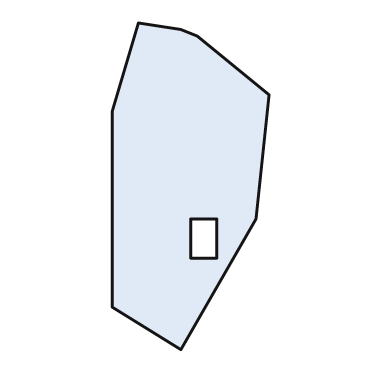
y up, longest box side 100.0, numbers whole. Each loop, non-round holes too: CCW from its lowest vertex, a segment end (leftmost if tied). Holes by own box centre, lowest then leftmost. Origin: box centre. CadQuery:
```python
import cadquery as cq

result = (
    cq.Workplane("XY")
    .moveTo(-3.0, -50.0)
    .lineTo(20.0, -10.0)
    .lineTo(24.0, 28.0)
    .lineTo(2.0, 46.0)
    .lineTo(-3.0, 48.0)
    .lineTo(-16.0, 50.0)
    .lineTo(-24.0, 23.0)
    .lineTo(-24.0, -37.0)
    .close()
    .moveTo(0.0, -22.0)
    .lineTo(8.0, -22.0)
    .lineTo(8.0, -10.0)
    .lineTo(0.0, -10.0)
    .close()
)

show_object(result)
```